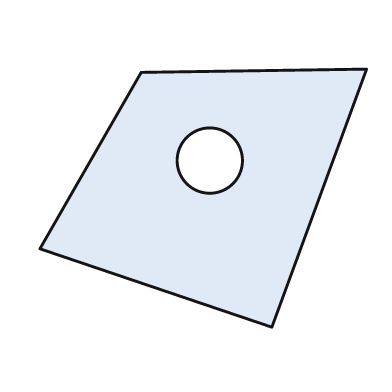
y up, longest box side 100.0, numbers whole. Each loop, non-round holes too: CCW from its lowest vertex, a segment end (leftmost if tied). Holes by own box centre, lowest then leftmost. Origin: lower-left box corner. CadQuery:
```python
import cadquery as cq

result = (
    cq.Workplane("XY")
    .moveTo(71.0, 0.0)
    .lineTo(100.0, 79.0)
    .lineTo(31.0, 78.0)
    .lineTo(0.0, 24.0)
    .close()
    .moveTo(52.0, 51.0)
    .circle(10.0)
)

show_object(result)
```